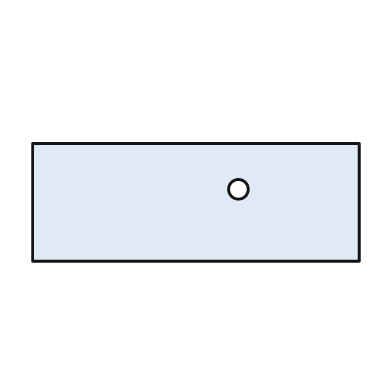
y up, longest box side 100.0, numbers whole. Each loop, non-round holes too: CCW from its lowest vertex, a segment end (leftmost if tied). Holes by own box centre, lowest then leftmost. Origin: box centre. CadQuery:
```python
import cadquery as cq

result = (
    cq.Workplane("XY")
    .moveTo(-50.0, -18.0)
    .lineTo(50.0, -18.0)
    .lineTo(50.0, 18.0)
    .lineTo(-50.0, 18.0)
    .close()
    .moveTo(13.0, 4.0)
    .circle(3.0)
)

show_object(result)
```